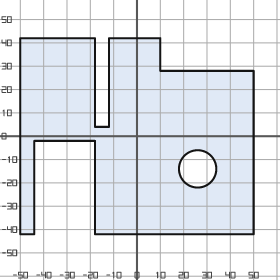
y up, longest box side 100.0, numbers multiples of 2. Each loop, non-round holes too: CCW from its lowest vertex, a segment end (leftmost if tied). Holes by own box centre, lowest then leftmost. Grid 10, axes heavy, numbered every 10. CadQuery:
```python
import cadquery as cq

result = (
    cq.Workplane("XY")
    .moveTo(-50.0, -42.0)
    .lineTo(-44.0, -42.0)
    .lineTo(-44.0, -2.0)
    .lineTo(-18.0, -2.0)
    .lineTo(-18.0, -42.0)
    .lineTo(50.0, -42.0)
    .lineTo(50.0, 28.0)
    .lineTo(10.0, 28.0)
    .lineTo(10.0, 42.0)
    .lineTo(-12.0, 42.0)
    .lineTo(-12.0, 4.0)
    .lineTo(-18.0, 4.0)
    .lineTo(-18.0, 42.0)
    .lineTo(-50.0, 42.0)
    .close()
    .moveTo(26.0, -14.0)
    .circle(8.0)
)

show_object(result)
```